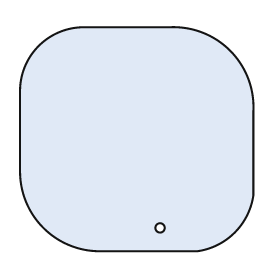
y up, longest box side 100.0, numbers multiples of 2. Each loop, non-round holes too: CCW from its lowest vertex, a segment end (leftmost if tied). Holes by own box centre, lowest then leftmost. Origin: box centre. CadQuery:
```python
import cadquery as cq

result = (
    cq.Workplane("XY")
    .moveTo(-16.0, -48.0)
    .lineTo(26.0, -48.0)
    .threePointArc((42.0, -40.0), (50.0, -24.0))
    .lineTo(50.0, 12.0)
    .threePointArc((40.0, 38.0), (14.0, 48.0))
    .lineTo(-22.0, 48.0)
    .threePointArc((-42.0, 40.0), (-50.0, 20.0))
    .lineTo(-50.0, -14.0)
    .threePointArc((-40.0, -38.0), (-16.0, -48.0))
    .close()
    .moveTo(10.0, -38.0)
    .circle(2.0)
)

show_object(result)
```